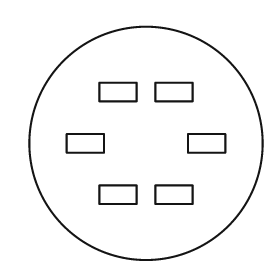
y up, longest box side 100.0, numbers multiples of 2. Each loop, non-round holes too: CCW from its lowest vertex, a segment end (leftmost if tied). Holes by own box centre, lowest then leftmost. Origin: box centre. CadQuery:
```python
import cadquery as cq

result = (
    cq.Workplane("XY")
    .moveTo(0.0, 0.0)
    .circle(50.0)
    .moveTo(-20.0, -26.0)
    .lineTo(-4.0, -26.0)
    .lineTo(-4.0, -18.0)
    .lineTo(-20.0, -18.0)
    .close()
    .moveTo(4.0, -26.0)
    .lineTo(20.0, -26.0)
    .lineTo(20.0, -18.0)
    .lineTo(4.0, -18.0)
    .close()
    .moveTo(-34.0, -4.0)
    .lineTo(-18.0, -4.0)
    .lineTo(-18.0, 4.0)
    .lineTo(-34.0, 4.0)
    .close()
    .moveTo(18.0, -4.0)
    .lineTo(34.0, -4.0)
    .lineTo(34.0, 4.0)
    .lineTo(18.0, 4.0)
    .close()
    .moveTo(-20.0, 18.0)
    .lineTo(-4.0, 18.0)
    .lineTo(-4.0, 26.0)
    .lineTo(-20.0, 26.0)
    .close()
    .moveTo(4.0, 18.0)
    .lineTo(20.0, 18.0)
    .lineTo(20.0, 26.0)
    .lineTo(4.0, 26.0)
    .close()
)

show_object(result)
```